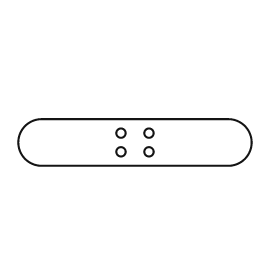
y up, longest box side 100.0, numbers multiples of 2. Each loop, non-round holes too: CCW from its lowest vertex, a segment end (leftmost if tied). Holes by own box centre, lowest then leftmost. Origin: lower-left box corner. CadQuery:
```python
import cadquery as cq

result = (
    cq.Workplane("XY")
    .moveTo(10.0, 0.0)
    .lineTo(90.0, 0.0)
    .threePointArc((100.0, 10.0), (90.0, 20.0))
    .lineTo(10.0, 20.0)
    .threePointArc((0.0, 10.0), (10.0, 0.0))
    .close()
    .moveTo(44.0, 6.0)
    .circle(2.0)
    .moveTo(56.0, 6.0)
    .circle(2.0)
    .moveTo(44.0, 14.0)
    .circle(2.0)
    .moveTo(56.0, 14.0)
    .circle(2.0)
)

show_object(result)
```